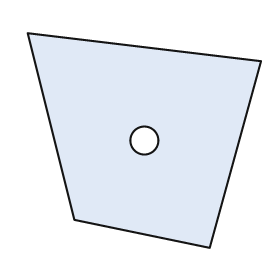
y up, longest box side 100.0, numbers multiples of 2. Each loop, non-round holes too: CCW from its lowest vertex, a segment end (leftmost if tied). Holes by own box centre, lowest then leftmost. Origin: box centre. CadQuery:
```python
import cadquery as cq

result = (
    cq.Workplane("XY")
    .moveTo(28.0, -46.0)
    .lineTo(50.0, 34.0)
    .lineTo(-50.0, 46.0)
    .lineTo(-30.0, -34.0)
    .close()
    .moveTo(0.0, 0.0)
    .circle(6.0)
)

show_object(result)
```